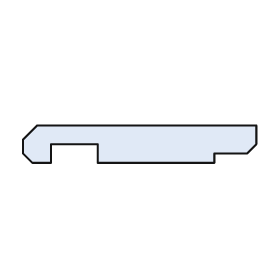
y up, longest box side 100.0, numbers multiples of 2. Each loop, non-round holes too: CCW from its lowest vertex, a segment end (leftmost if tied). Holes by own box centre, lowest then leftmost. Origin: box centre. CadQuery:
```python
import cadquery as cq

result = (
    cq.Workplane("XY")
    .moveTo(-46.0, -8.0)
    .lineTo(-38.0, -8.0)
    .lineTo(-38.0, 0.0)
    .lineTo(-18.0, 0.0)
    .lineTo(-18.0, -8.0)
    .lineTo(32.0, -8.0)
    .lineTo(32.0, -4.0)
    .lineTo(46.0, -4.0)
    .lineTo(50.0, 0.0)
    .lineTo(50.0, 8.0)
    .lineTo(-44.0, 8.0)
    .lineTo(-50.0, 2.0)
    .lineTo(-50.0, -4.0)
    .close()
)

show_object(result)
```